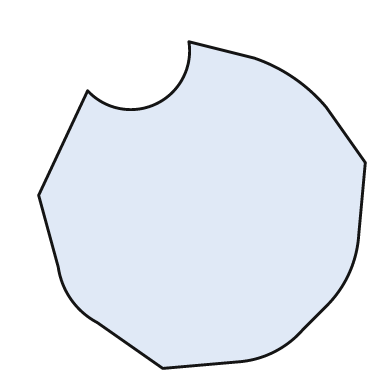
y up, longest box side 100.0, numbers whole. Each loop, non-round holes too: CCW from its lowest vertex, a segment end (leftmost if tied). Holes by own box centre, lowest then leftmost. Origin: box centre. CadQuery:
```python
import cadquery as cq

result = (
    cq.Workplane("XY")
    .moveTo(-12.0, -50.0)
    .lineTo(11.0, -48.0)
    .threePointArc((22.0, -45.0), (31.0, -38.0))
    .lineTo(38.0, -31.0)
    .threePointArc((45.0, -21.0), (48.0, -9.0))
    .lineTo(50.0, 13.0)
    .lineTo(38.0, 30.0)
    .threePointArc((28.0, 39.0), (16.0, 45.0))
    .lineTo(-4.0, 50.0)
    .threePointArc((-14.0, 31.0), (-35.0, 35.0))
    .lineTo(-50.0, 3.0)
    .lineTo(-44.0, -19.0)
    .threePointArc((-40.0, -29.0), (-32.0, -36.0))
    .close()
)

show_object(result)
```